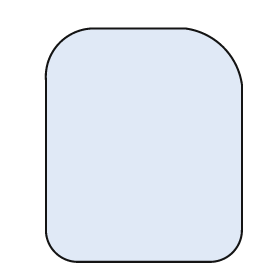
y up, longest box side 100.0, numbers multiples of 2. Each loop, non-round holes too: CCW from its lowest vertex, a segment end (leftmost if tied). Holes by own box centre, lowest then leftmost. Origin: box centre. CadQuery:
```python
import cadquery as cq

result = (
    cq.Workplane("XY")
    .moveTo(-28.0, -50.0)
    .lineTo(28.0, -50.0)
    .threePointArc((38.0, -46.0), (42.0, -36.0))
    .lineTo(42.0, 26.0)
    .threePointArc((34.0, 42.0), (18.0, 50.0))
    .lineTo(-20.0, 50.0)
    .threePointArc((-36.0, 44.0), (-42.0, 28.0))
    .lineTo(-42.0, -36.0)
    .threePointArc((-38.0, -46.0), (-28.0, -50.0))
    .close()
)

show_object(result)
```